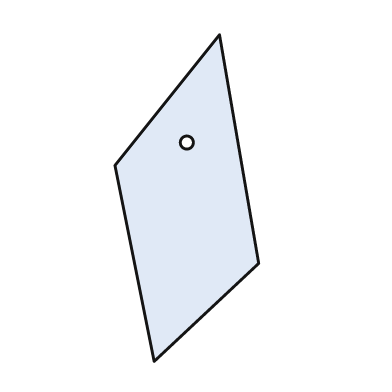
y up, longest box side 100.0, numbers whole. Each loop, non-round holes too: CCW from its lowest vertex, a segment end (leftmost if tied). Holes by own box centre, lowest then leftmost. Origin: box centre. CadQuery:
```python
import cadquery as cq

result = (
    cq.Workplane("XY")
    .moveTo(-10.0, -50.0)
    .lineTo(22.0, -20.0)
    .lineTo(10.0, 50.0)
    .lineTo(-22.0, 10.0)
    .close()
    .moveTo(0.0, 17.0)
    .circle(2.0)
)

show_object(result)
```